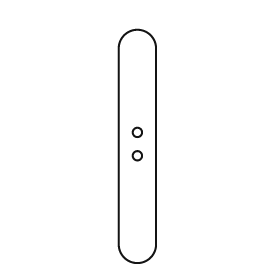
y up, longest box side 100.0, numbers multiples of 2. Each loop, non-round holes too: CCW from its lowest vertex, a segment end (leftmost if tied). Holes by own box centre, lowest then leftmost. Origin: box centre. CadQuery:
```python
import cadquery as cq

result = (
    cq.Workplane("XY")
    .moveTo(-8.0, -42.0)
    .threePointArc((0.0, -50.0), (8.0, -42.0))
    .lineTo(8.0, 42.0)
    .threePointArc((0.0, 50.0), (-8.0, 42.0))
    .close()
    .moveTo(0.0, -4.0)
    .circle(2.0)
    .moveTo(0.0, 6.0)
    .circle(2.0)
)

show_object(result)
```